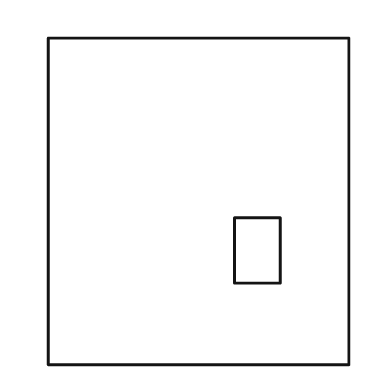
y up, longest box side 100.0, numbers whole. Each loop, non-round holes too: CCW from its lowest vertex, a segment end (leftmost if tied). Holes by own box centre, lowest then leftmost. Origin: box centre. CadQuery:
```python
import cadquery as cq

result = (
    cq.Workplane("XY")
    .moveTo(-46.0, -50.0)
    .lineTo(46.0, -50.0)
    .lineTo(46.0, 50.0)
    .lineTo(-46.0, 50.0)
    .close()
    .moveTo(11.0, -25.0)
    .lineTo(25.0, -25.0)
    .lineTo(25.0, -5.0)
    .lineTo(11.0, -5.0)
    .close()
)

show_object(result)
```